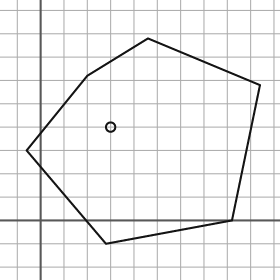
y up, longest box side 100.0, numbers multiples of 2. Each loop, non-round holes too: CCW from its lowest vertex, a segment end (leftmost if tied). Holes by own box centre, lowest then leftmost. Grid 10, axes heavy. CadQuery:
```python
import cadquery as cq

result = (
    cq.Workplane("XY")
    .moveTo(28.0, -10.0)
    .lineTo(82.0, 0.0)
    .lineTo(94.0, 58.0)
    .lineTo(46.0, 78.0)
    .lineTo(20.0, 62.0)
    .lineTo(-6.0, 30.0)
    .close()
    .moveTo(30.0, 40.0)
    .circle(2.0)
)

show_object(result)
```